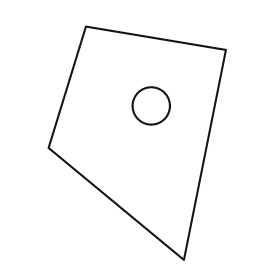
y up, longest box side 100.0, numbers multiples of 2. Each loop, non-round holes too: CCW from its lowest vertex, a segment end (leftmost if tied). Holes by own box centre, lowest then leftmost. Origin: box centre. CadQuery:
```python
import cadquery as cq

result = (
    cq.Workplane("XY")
    .moveTo(20.0, -50.0)
    .lineTo(38.0, 40.0)
    .lineTo(-22.0, 50.0)
    .lineTo(-38.0, -2.0)
    .close()
    .moveTo(6.0, 16.0)
    .circle(8.0)
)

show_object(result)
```